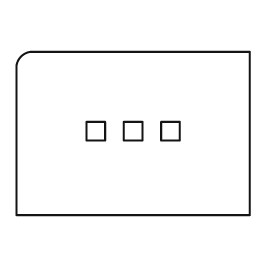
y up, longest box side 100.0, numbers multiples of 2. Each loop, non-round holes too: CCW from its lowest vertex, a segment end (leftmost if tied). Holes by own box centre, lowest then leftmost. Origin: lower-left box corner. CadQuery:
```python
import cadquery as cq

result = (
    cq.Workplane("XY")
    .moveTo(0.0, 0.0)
    .lineTo(100.0, 0.0)
    .lineTo(100.0, 70.0)
    .lineTo(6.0, 70.0)
    .threePointArc((2.0, 68.0), (0.0, 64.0))
    .close()
    .moveTo(30.0, 32.0)
    .lineTo(38.0, 32.0)
    .lineTo(38.0, 40.0)
    .lineTo(30.0, 40.0)
    .close()
    .moveTo(46.0, 32.0)
    .lineTo(54.0, 32.0)
    .lineTo(54.0, 40.0)
    .lineTo(46.0, 40.0)
    .close()
    .moveTo(62.0, 32.0)
    .lineTo(70.0, 32.0)
    .lineTo(70.0, 40.0)
    .lineTo(62.0, 40.0)
    .close()
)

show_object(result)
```